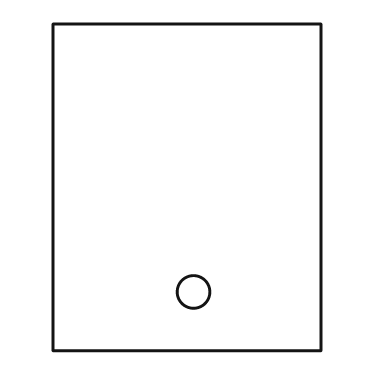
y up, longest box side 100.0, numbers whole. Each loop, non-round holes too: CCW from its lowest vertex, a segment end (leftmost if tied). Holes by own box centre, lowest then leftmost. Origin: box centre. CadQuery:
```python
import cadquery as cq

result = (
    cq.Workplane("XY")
    .moveTo(-41.0, -50.0)
    .lineTo(41.0, -50.0)
    .lineTo(41.0, 50.0)
    .lineTo(-41.0, 50.0)
    .close()
    .moveTo(2.0, -32.0)
    .circle(5.0)
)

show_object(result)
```